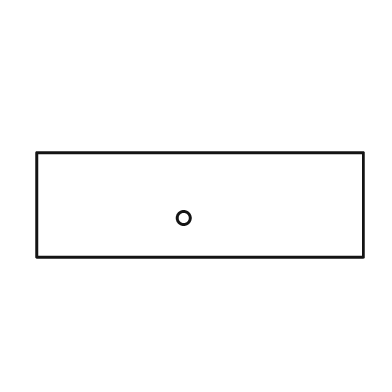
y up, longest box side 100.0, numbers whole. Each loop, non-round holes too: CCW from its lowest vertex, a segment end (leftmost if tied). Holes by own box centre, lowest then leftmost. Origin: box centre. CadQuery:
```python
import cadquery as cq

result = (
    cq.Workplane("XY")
    .moveTo(-50.0, -16.0)
    .lineTo(50.0, -16.0)
    .lineTo(50.0, 16.0)
    .lineTo(-50.0, 16.0)
    .close()
    .moveTo(-5.0, -4.0)
    .circle(2.0)
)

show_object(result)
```